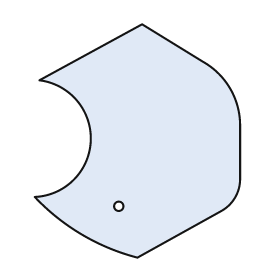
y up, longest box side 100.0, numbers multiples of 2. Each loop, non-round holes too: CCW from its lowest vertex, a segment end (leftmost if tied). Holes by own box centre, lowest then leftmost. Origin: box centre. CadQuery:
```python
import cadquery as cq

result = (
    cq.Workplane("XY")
    .moveTo(0.0, -50.0)
    .lineTo(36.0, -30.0)
    .threePointArc((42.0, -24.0), (44.0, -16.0))
    .lineTo(44.0, 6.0)
    .threePointArc((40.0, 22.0), (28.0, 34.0))
    .lineTo(2.0, 50.0)
    .lineTo(-42.0, 26.0)
    .threePointArc((-20.0, 0.0), (-44.0, -24.0))
    .threePointArc((-24.0, -40.0), (0.0, -50.0))
    .close()
    .moveTo(-8.0, -28.0)
    .circle(2.0)
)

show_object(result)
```